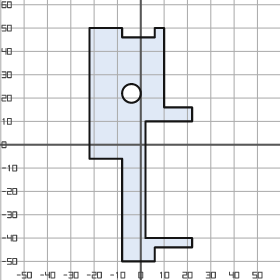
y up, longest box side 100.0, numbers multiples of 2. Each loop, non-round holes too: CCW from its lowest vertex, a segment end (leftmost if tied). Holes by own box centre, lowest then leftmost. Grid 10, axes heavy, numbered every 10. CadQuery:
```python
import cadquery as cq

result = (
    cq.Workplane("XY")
    .moveTo(-8.0, -50.0)
    .lineTo(6.0, -50.0)
    .lineTo(6.0, -44.0)
    .lineTo(22.0, -44.0)
    .lineTo(22.0, -40.0)
    .lineTo(2.0, -40.0)
    .lineTo(2.0, 10.0)
    .lineTo(22.0, 10.0)
    .lineTo(22.0, 16.0)
    .lineTo(10.0, 16.0)
    .lineTo(10.0, 50.0)
    .lineTo(6.0, 50.0)
    .lineTo(6.0, 46.0)
    .lineTo(-8.0, 46.0)
    .lineTo(-8.0, 50.0)
    .lineTo(-22.0, 50.0)
    .lineTo(-22.0, -6.0)
    .lineTo(-8.0, -6.0)
    .close()
    .moveTo(-4.0, 22.0)
    .circle(4.0)
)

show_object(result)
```